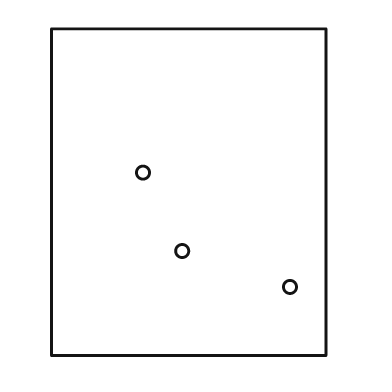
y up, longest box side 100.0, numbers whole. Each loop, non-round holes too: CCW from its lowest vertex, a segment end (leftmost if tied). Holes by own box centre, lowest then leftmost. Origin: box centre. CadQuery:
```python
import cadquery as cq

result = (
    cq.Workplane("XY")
    .moveTo(-42.0, -50.0)
    .lineTo(42.0, -50.0)
    .lineTo(42.0, 50.0)
    .lineTo(-42.0, 50.0)
    .close()
    .moveTo(31.0, -29.0)
    .circle(2.0)
    .moveTo(-2.0, -18.0)
    .circle(2.0)
    .moveTo(-14.0, 6.0)
    .circle(2.0)
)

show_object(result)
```